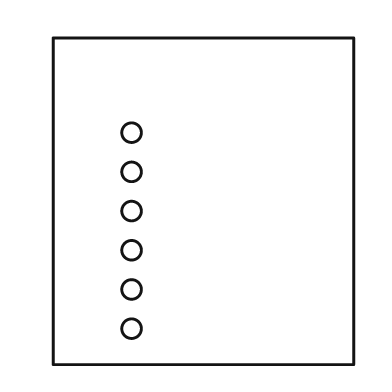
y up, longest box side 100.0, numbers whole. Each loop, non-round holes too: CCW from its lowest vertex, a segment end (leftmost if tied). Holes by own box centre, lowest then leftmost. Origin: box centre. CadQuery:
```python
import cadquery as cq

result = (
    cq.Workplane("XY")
    .moveTo(-46.0, -50.0)
    .lineTo(46.0, -50.0)
    .lineTo(46.0, 50.0)
    .lineTo(-46.0, 50.0)
    .close()
    .moveTo(-22.0, -39.0)
    .circle(3.0)
    .moveTo(-22.0, -27.0)
    .circle(3.0)
    .moveTo(-22.0, -15.0)
    .circle(3.0)
    .moveTo(-22.0, -3.0)
    .circle(3.0)
    .moveTo(-22.0, 9.0)
    .circle(3.0)
    .moveTo(-22.0, 21.0)
    .circle(3.0)
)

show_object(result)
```